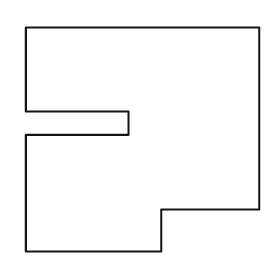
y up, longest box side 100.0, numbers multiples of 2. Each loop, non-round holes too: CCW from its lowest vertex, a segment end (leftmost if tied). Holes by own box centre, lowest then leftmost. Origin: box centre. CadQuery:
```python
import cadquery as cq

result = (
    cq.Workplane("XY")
    .moveTo(-50.0, -48.0)
    .lineTo(8.0, -48.0)
    .lineTo(8.0, -30.0)
    .lineTo(50.0, -30.0)
    .lineTo(50.0, 48.0)
    .lineTo(-50.0, 48.0)
    .lineTo(-50.0, 12.0)
    .lineTo(-6.0, 12.0)
    .lineTo(-6.0, 2.0)
    .lineTo(-50.0, 2.0)
    .close()
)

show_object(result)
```